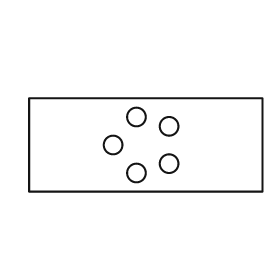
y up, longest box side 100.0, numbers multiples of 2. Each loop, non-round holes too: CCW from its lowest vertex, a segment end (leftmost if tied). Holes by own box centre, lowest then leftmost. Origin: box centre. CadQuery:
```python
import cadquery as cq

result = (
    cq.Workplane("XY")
    .moveTo(-50.0, -20.0)
    .lineTo(50.0, -20.0)
    .lineTo(50.0, 20.0)
    .lineTo(-50.0, 20.0)
    .close()
    .moveTo(-4.0, -12.0)
    .circle(4.0)
    .moveTo(10.0, -8.0)
    .circle(4.0)
    .moveTo(-14.0, 0.0)
    .circle(4.0)
    .moveTo(10.0, 8.0)
    .circle(4.0)
    .moveTo(-4.0, 12.0)
    .circle(4.0)
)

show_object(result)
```